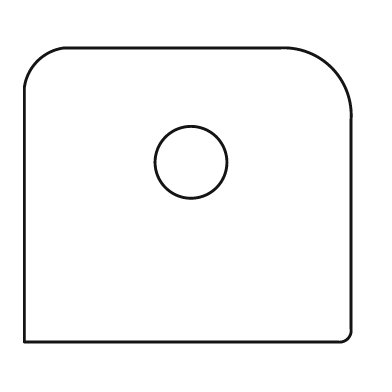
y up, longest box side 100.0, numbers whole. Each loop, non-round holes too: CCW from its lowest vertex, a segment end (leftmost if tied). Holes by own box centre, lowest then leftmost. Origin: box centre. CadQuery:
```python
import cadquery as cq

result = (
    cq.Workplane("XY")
    .moveTo(-50.0, -45.0)
    .lineTo(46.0, -45.0)
    .threePointArc((49.0, -44.0), (50.0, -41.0))
    .lineTo(50.0, 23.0)
    .threePointArc((44.0, 39.0), (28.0, 45.0))
    .lineTo(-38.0, 45.0)
    .threePointArc((-46.0, 41.0), (-50.0, 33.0))
    .close()
    .moveTo(1.0, 10.0)
    .circle(11.0)
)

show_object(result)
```